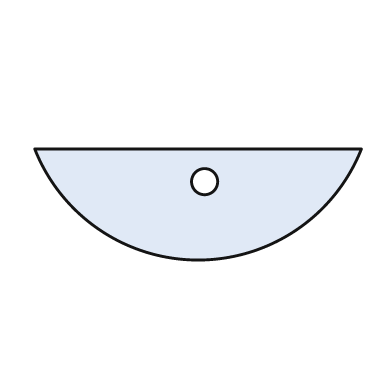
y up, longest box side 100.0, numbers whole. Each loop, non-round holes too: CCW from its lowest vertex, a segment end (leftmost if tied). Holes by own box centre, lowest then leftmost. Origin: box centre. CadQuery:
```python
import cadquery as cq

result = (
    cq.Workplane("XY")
    .moveTo(-50.0, 17.0)
    .threePointArc((0.0, -17.0), (50.0, 17.0))
    .close()
    .moveTo(2.0, 7.0)
    .circle(4.0)
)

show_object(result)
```